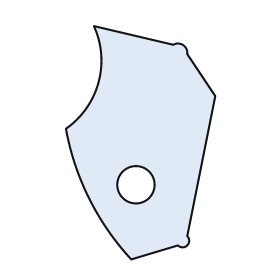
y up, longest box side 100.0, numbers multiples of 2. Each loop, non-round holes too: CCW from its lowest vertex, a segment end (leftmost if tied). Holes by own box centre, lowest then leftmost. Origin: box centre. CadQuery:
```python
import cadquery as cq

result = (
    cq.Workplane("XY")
    .moveTo(-4.0, -50.0)
    .lineTo(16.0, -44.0)
    .threePointArc((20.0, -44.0), (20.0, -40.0))
    .lineTo(32.0, 20.0)
    .lineTo(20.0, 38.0)
    .threePointArc((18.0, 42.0), (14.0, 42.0))
    .lineTo(-20.0, 50.0)
    .threePointArc((-18.0, 26.0), (-32.0, 6.0))
    .threePointArc((-22.0, -24.0), (-4.0, -50.0))
    .close()
    .moveTo(-2.0, -18.0)
    .circle(8.0)
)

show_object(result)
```